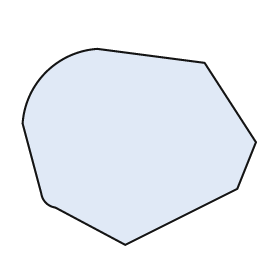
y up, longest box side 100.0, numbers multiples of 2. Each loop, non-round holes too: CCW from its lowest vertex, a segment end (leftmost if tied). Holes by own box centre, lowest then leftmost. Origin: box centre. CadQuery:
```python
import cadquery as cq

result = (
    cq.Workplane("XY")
    .moveTo(-6.0, -42.0)
    .lineTo(42.0, -18.0)
    .lineTo(50.0, 2.0)
    .lineTo(28.0, 36.0)
    .lineTo(-18.0, 42.0)
    .threePointArc((-40.0, 32.0), (-50.0, 10.0))
    .lineTo(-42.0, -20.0)
    .threePointArc((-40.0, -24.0), (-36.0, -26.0))
    .close()
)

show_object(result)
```